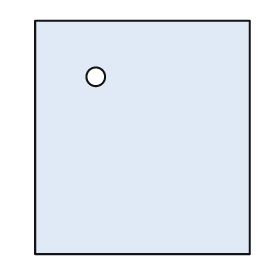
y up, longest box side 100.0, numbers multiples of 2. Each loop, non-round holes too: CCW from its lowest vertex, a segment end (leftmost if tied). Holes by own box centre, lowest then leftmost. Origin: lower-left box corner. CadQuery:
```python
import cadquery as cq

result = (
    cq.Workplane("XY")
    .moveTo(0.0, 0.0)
    .lineTo(92.0, 0.0)
    .lineTo(92.0, 100.0)
    .lineTo(0.0, 100.0)
    .close()
    .moveTo(26.0, 76.0)
    .circle(4.0)
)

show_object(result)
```